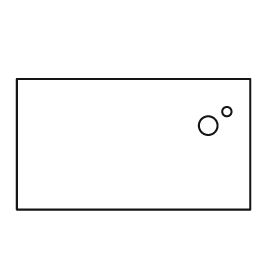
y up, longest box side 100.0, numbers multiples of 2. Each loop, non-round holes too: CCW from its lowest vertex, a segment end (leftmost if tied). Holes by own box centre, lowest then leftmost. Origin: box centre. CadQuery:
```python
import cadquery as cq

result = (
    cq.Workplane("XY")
    .moveTo(-50.0, -28.0)
    .lineTo(50.0, -28.0)
    .lineTo(50.0, 28.0)
    .lineTo(-50.0, 28.0)
    .close()
    .moveTo(32.0, 8.0)
    .circle(4.0)
    .moveTo(40.0, 14.0)
    .circle(2.0)
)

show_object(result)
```